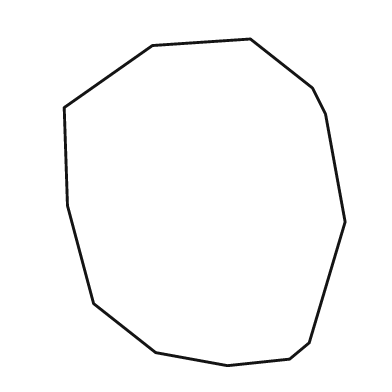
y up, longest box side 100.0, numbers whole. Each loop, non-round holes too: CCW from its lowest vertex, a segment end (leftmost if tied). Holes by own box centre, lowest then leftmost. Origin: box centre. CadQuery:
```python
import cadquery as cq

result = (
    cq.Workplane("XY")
    .moveTo(7.0, -50.0)
    .lineTo(26.0, -48.0)
    .lineTo(32.0, -43.0)
    .lineTo(43.0, -6.0)
    .lineTo(37.0, 27.0)
    .lineTo(33.0, 35.0)
    .lineTo(14.0, 50.0)
    .lineTo(-16.0, 48.0)
    .lineTo(-43.0, 29.0)
    .lineTo(-42.0, -1.0)
    .lineTo(-34.0, -31.0)
    .lineTo(-15.0, -46.0)
    .close()
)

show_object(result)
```